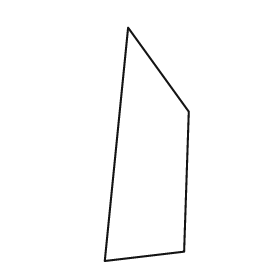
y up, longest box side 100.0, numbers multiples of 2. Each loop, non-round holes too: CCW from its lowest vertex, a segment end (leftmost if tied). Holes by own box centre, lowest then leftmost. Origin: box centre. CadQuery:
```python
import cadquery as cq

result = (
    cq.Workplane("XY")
    .moveTo(-18.0, -50.0)
    .lineTo(16.0, -46.0)
    .lineTo(18.0, 14.0)
    .lineTo(-8.0, 50.0)
    .close()
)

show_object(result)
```